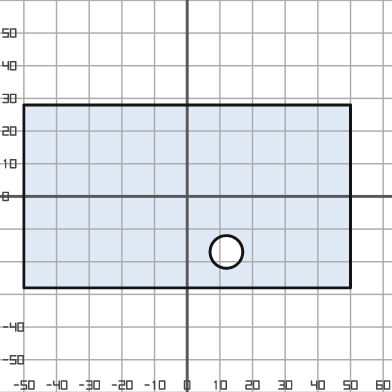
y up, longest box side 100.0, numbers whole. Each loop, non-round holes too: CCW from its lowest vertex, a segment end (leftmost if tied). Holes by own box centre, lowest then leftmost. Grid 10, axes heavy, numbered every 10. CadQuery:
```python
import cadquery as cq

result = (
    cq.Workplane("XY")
    .moveTo(-50.0, -28.0)
    .lineTo(50.0, -28.0)
    .lineTo(50.0, 28.0)
    .lineTo(-50.0, 28.0)
    .close()
    .moveTo(12.0, -17.0)
    .circle(5.0)
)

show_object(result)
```